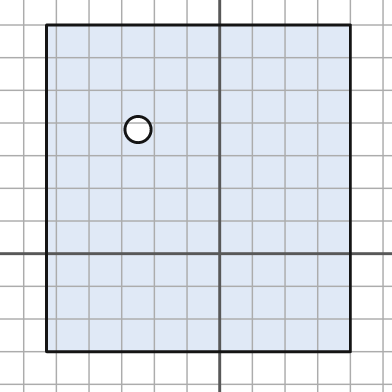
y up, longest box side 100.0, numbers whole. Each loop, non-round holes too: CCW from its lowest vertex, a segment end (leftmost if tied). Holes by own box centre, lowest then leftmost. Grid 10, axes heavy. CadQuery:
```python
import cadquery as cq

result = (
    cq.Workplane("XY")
    .moveTo(-53.0, -30.0)
    .lineTo(40.0, -30.0)
    .lineTo(40.0, 70.0)
    .lineTo(-53.0, 70.0)
    .close()
    .moveTo(-25.0, 38.0)
    .circle(4.0)
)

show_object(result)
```